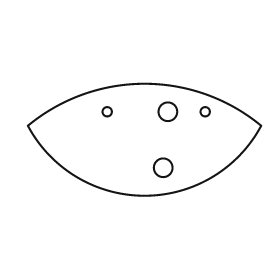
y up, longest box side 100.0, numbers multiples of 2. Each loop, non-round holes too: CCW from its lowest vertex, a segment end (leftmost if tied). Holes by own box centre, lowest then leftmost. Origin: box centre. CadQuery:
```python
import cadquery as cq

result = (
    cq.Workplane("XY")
    .moveTo(-50.0, 6.0)
    .threePointArc((0.0, -24.0), (50.0, 6.0))
    .threePointArc((0.0, 24.0), (-50.0, 6.0))
    .close()
    .moveTo(8.0, -12.0)
    .circle(4.0)
    .moveTo(-16.0, 12.0)
    .circle(2.0)
    .moveTo(10.0, 12.0)
    .circle(4.0)
    .moveTo(26.0, 12.0)
    .circle(2.0)
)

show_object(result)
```